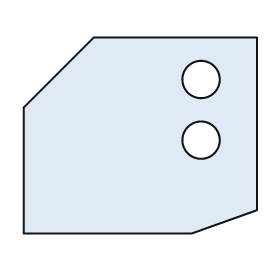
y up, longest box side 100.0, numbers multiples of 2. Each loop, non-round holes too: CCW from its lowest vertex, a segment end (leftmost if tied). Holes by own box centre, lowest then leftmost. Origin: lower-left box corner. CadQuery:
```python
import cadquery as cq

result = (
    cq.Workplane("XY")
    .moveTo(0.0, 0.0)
    .lineTo(72.0, 0.0)
    .lineTo(100.0, 10.0)
    .lineTo(100.0, 84.0)
    .lineTo(30.0, 84.0)
    .lineTo(0.0, 54.0)
    .close()
    .moveTo(76.0, 40.0)
    .circle(8.0)
    .moveTo(76.0, 66.0)
    .circle(8.0)
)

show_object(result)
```